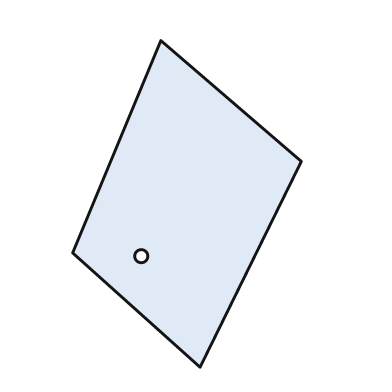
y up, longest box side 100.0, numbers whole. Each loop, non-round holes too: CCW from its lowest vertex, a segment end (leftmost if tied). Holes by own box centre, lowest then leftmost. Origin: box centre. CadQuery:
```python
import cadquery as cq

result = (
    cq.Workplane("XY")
    .moveTo(4.0, -50.0)
    .lineTo(35.0, 13.0)
    .lineTo(-8.0, 50.0)
    .lineTo(-35.0, -15.0)
    .close()
    .moveTo(-14.0, -16.0)
    .circle(2.0)
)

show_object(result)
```